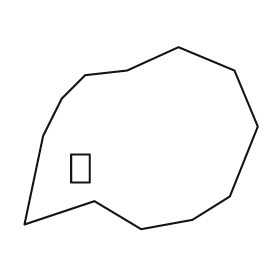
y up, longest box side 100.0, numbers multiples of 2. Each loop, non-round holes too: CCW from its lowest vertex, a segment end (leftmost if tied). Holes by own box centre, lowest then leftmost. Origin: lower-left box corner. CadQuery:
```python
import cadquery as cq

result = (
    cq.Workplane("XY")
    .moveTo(50.0, 0.0)
    .lineTo(72.0, 4.0)
    .lineTo(88.0, 14.0)
    .lineTo(100.0, 44.0)
    .lineTo(90.0, 68.0)
    .lineTo(66.0, 78.0)
    .lineTo(44.0, 68.0)
    .lineTo(26.0, 66.0)
    .lineTo(16.0, 56.0)
    .lineTo(8.0, 40.0)
    .lineTo(0.0, 2.0)
    .lineTo(30.0, 12.0)
    .close()
    .moveTo(20.0, 20.0)
    .lineTo(28.0, 20.0)
    .lineTo(28.0, 32.0)
    .lineTo(20.0, 32.0)
    .close()
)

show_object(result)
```